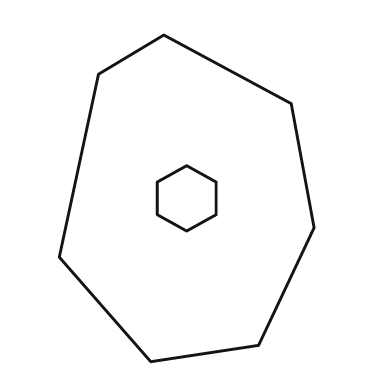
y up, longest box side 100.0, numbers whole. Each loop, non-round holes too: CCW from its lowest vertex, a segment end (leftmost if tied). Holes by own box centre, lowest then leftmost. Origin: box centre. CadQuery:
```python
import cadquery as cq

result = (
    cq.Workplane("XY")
    .moveTo(-11.0, -50.0)
    .lineTo(22.0, -45.0)
    .lineTo(39.0, -9.0)
    .lineTo(32.0, 29.0)
    .lineTo(-7.0, 50.0)
    .lineTo(-27.0, 38.0)
    .lineTo(-39.0, -18.0)
    .close()
    .moveTo(0.0, -10.0)
    .lineTo(9.0, -5.0)
    .lineTo(9.0, 5.0)
    .lineTo(0.0, 10.0)
    .lineTo(-9.0, 5.0)
    .lineTo(-9.0, -5.0)
    .close()
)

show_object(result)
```